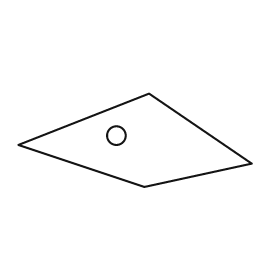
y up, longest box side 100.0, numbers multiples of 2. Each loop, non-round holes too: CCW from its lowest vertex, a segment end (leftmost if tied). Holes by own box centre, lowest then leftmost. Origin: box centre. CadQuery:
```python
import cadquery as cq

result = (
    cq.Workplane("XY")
    .moveTo(4.0, -20.0)
    .lineTo(50.0, -10.0)
    .lineTo(6.0, 20.0)
    .lineTo(-50.0, -2.0)
    .close()
    .moveTo(-8.0, 2.0)
    .circle(4.0)
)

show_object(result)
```